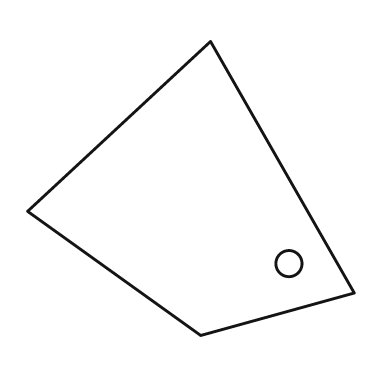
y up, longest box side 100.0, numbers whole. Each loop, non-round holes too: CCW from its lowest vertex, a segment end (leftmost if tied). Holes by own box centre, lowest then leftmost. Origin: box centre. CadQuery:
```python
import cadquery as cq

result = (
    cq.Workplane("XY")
    .moveTo(3.0, -45.0)
    .lineTo(50.0, -32.0)
    .lineTo(6.0, 45.0)
    .lineTo(-50.0, -7.0)
    .close()
    .moveTo(30.0, -23.0)
    .circle(4.0)
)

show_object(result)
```